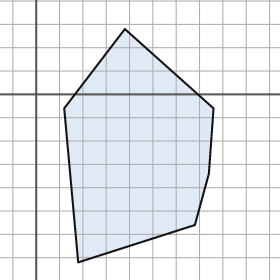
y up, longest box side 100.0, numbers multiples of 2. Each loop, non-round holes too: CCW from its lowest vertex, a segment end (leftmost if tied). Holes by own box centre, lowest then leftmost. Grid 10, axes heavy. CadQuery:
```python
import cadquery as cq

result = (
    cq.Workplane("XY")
    .moveTo(18.0, -72.0)
    .lineTo(68.0, -56.0)
    .lineTo(74.0, -34.0)
    .lineTo(76.0, -6.0)
    .lineTo(38.0, 28.0)
    .lineTo(12.0, -6.0)
    .close()
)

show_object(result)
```